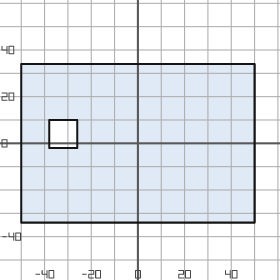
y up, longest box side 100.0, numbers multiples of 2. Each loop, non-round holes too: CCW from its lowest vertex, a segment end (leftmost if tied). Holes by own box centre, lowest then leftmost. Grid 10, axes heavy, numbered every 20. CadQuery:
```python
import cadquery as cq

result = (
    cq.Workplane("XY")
    .moveTo(-50.0, -34.0)
    .lineTo(50.0, -34.0)
    .lineTo(50.0, 34.0)
    .lineTo(-50.0, 34.0)
    .close()
    .moveTo(-38.0, -2.0)
    .lineTo(-26.0, -2.0)
    .lineTo(-26.0, 10.0)
    .lineTo(-38.0, 10.0)
    .close()
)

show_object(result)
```